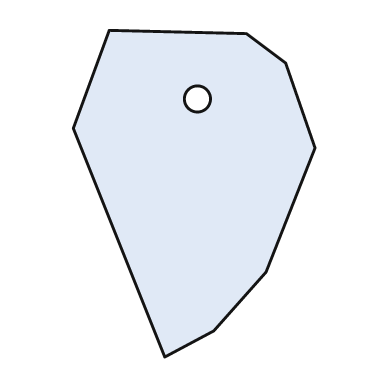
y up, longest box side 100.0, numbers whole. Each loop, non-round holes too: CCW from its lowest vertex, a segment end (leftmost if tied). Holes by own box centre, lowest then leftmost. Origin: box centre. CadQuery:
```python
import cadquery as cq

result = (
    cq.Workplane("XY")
    .moveTo(-9.0, -50.0)
    .lineTo(6.0, -42.0)
    .lineTo(22.0, -24.0)
    .lineTo(37.0, 14.0)
    .lineTo(28.0, 40.0)
    .lineTo(16.0, 49.0)
    .lineTo(-26.0, 50.0)
    .lineTo(-37.0, 20.0)
    .close()
    .moveTo(1.0, 29.0)
    .circle(4.0)
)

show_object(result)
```